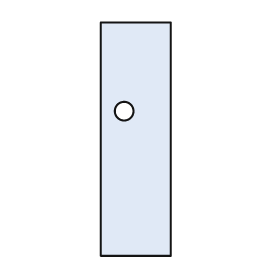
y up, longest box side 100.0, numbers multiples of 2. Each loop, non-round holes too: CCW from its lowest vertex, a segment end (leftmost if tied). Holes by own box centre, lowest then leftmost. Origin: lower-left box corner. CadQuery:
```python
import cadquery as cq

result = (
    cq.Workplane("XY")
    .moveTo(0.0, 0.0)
    .lineTo(30.0, 0.0)
    .lineTo(30.0, 100.0)
    .lineTo(0.0, 100.0)
    .close()
    .moveTo(10.0, 62.0)
    .circle(4.0)
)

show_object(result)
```